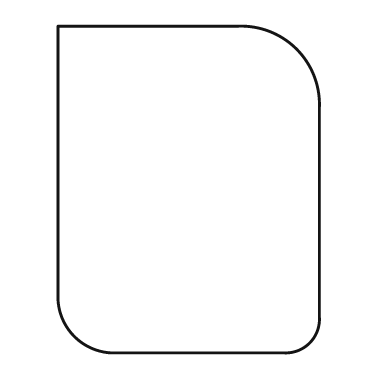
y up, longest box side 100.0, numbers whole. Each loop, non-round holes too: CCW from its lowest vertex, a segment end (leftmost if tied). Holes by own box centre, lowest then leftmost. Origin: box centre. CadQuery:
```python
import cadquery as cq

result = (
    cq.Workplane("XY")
    .moveTo(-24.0, -50.0)
    .lineTo(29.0, -50.0)
    .threePointArc((37.0, -47.0), (40.0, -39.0))
    .lineTo(40.0, 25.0)
    .threePointArc((33.0, 43.0), (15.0, 50.0))
    .lineTo(-40.0, 50.0)
    .lineTo(-40.0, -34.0)
    .threePointArc((-35.0, -45.0), (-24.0, -50.0))
    .close()
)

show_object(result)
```